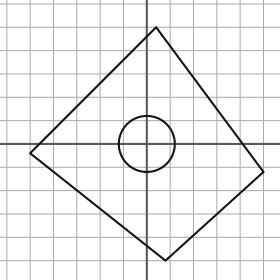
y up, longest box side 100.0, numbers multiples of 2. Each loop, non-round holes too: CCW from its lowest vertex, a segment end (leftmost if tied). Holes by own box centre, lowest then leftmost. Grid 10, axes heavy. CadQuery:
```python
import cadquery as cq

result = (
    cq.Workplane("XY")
    .moveTo(8.0, -50.0)
    .lineTo(50.0, -12.0)
    .lineTo(4.0, 50.0)
    .lineTo(-50.0, -4.0)
    .close()
    .moveTo(0.0, 0.0)
    .circle(12.0)
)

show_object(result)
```